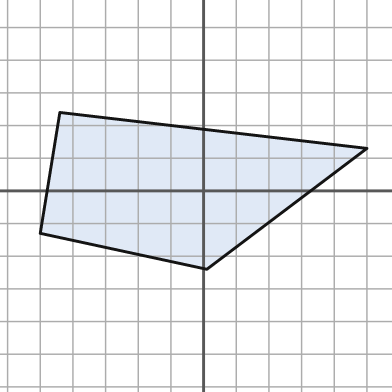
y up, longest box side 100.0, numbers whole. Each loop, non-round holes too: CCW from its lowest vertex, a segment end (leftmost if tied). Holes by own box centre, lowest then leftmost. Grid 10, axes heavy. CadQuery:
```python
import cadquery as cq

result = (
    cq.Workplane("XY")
    .moveTo(1.0, -24.0)
    .lineTo(50.0, 13.0)
    .lineTo(-44.0, 24.0)
    .lineTo(-50.0, -13.0)
    .close()
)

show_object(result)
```